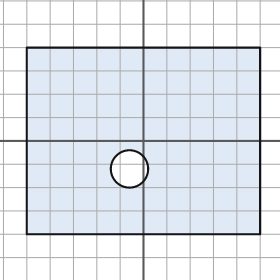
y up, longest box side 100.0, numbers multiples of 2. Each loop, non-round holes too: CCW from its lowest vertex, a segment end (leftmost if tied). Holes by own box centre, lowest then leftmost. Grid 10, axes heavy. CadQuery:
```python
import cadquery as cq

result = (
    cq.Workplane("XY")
    .moveTo(-50.0, -40.0)
    .lineTo(50.0, -40.0)
    .lineTo(50.0, 40.0)
    .lineTo(-50.0, 40.0)
    .close()
    .moveTo(-6.0, -12.0)
    .circle(8.0)
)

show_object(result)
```